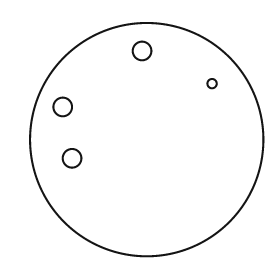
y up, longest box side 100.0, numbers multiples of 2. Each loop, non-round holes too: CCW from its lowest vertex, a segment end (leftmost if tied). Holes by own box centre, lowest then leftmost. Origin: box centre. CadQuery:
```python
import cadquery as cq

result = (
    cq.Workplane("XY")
    .moveTo(0.0, 0.0)
    .circle(50.0)
    .moveTo(-32.0, -8.0)
    .circle(4.0)
    .moveTo(-36.0, 14.0)
    .circle(4.0)
    .moveTo(28.0, 24.0)
    .circle(2.0)
    .moveTo(-2.0, 38.0)
    .circle(4.0)
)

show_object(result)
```